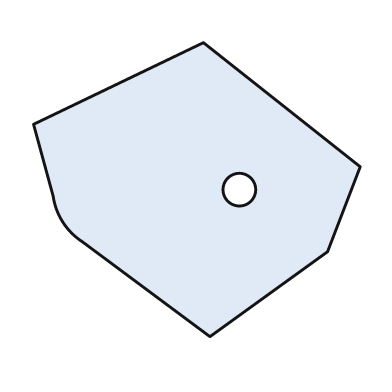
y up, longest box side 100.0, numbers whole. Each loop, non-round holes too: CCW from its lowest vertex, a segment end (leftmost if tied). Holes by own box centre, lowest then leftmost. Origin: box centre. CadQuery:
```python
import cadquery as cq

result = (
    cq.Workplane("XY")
    .moveTo(4.0, -45.0)
    .lineTo(40.0, -19.0)
    .lineTo(50.0, 7.0)
    .lineTo(2.0, 45.0)
    .lineTo(-50.0, 20.0)
    .lineTo(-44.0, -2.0)
    .threePointArc((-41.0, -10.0), (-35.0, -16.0))
    .close()
    .moveTo(13.0, 0.0)
    .circle(5.0)
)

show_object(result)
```